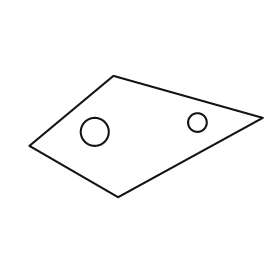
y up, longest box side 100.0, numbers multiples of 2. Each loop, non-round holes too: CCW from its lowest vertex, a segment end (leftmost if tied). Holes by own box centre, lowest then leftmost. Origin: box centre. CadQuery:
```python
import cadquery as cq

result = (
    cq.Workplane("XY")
    .moveTo(-12.0, -26.0)
    .lineTo(50.0, 8.0)
    .lineTo(-14.0, 26.0)
    .lineTo(-50.0, -4.0)
    .close()
    .moveTo(-22.0, 2.0)
    .circle(6.0)
    .moveTo(22.0, 6.0)
    .circle(4.0)
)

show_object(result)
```